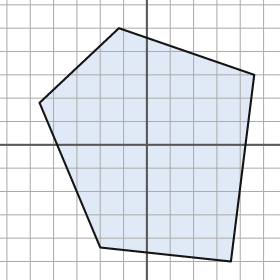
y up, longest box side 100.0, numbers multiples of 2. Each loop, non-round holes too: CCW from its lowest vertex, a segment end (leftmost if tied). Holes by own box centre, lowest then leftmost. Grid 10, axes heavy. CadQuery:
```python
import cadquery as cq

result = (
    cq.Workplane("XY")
    .moveTo(36.0, -50.0)
    .lineTo(46.0, 30.0)
    .lineTo(-12.0, 50.0)
    .lineTo(-46.0, 18.0)
    .lineTo(-20.0, -44.0)
    .close()
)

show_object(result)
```